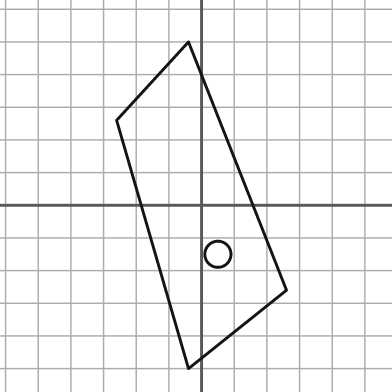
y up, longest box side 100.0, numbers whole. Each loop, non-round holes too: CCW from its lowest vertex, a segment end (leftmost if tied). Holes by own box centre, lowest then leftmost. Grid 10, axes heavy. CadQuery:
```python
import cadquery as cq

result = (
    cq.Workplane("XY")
    .moveTo(-4.0, -50.0)
    .lineTo(26.0, -26.0)
    .lineTo(-4.0, 50.0)
    .lineTo(-26.0, 26.0)
    .close()
    .moveTo(5.0, -15.0)
    .circle(4.0)
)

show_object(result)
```